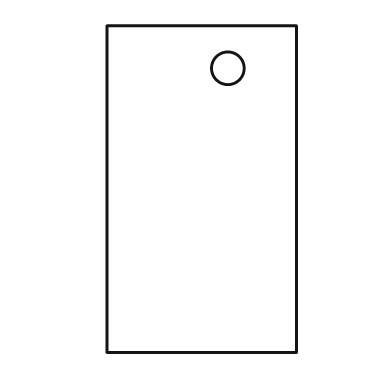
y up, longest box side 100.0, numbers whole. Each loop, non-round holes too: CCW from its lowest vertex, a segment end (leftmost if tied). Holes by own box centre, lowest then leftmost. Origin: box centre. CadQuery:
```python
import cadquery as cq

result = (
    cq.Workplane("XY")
    .moveTo(-29.0, -50.0)
    .lineTo(29.0, -50.0)
    .lineTo(29.0, 50.0)
    .lineTo(-29.0, 50.0)
    .close()
    .moveTo(8.0, 37.0)
    .circle(5.0)
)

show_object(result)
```